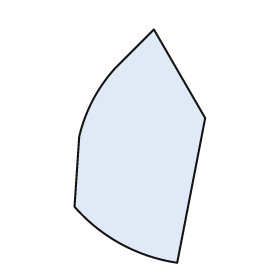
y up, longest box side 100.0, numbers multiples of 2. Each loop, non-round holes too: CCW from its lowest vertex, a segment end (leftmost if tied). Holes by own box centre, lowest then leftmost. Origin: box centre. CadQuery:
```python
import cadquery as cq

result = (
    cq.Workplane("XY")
    .moveTo(16.0, -50.0)
    .lineTo(28.0, 12.0)
    .lineTo(6.0, 50.0)
    .lineTo(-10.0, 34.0)
    .threePointArc((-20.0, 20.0), (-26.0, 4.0))
    .lineTo(-28.0, -26.0)
    .threePointArc((-8.0, -42.0), (16.0, -50.0))
    .close()
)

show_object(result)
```